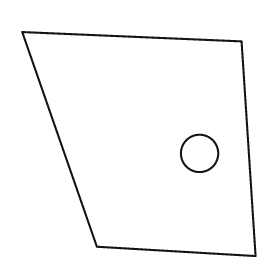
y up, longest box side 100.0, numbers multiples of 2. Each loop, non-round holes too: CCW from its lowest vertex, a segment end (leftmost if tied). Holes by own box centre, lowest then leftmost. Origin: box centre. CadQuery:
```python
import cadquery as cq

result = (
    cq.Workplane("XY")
    .moveTo(50.0, -48.0)
    .lineTo(44.0, 44.0)
    .lineTo(-50.0, 48.0)
    .lineTo(-18.0, -44.0)
    .close()
    .moveTo(26.0, -4.0)
    .circle(8.0)
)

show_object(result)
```